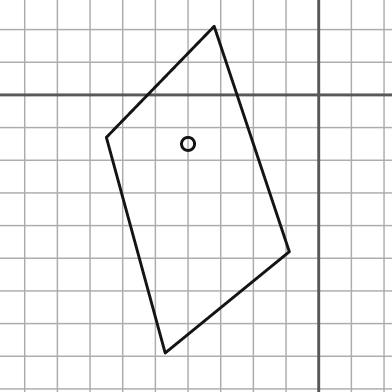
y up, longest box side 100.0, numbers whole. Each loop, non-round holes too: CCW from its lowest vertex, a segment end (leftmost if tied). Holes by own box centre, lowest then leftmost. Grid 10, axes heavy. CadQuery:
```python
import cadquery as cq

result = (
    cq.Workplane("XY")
    .moveTo(-47.0, -79.0)
    .lineTo(-9.0, -48.0)
    .lineTo(-32.0, 21.0)
    .lineTo(-65.0, -13.0)
    .close()
    .moveTo(-40.0, -15.0)
    .circle(2.0)
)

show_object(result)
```